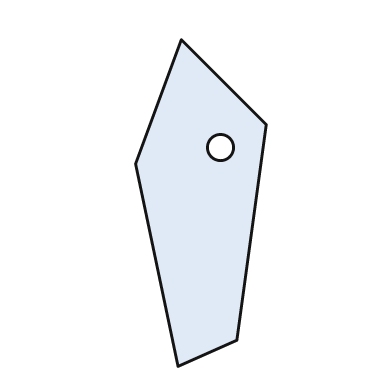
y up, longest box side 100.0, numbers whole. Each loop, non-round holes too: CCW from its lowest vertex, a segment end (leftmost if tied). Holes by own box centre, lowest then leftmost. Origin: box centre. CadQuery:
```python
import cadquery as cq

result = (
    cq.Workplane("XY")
    .moveTo(-7.0, -50.0)
    .lineTo(11.0, -42.0)
    .lineTo(20.0, 24.0)
    .lineTo(-6.0, 50.0)
    .lineTo(-20.0, 12.0)
    .close()
    .moveTo(6.0, 17.0)
    .circle(4.0)
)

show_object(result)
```